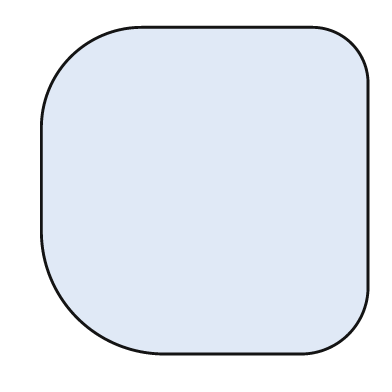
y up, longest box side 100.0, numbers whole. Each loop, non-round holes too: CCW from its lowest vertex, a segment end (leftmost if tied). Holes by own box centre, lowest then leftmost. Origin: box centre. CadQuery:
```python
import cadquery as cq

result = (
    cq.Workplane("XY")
    .moveTo(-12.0, -50.0)
    .lineTo(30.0, -50.0)
    .threePointArc((44.0, -44.0), (50.0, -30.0))
    .lineTo(50.0, 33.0)
    .threePointArc((45.0, 45.0), (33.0, 50.0))
    .lineTo(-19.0, 50.0)
    .threePointArc((-41.0, 41.0), (-50.0, 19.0))
    .lineTo(-50.0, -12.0)
    .threePointArc((-39.0, -39.0), (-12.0, -50.0))
    .close()
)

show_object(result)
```